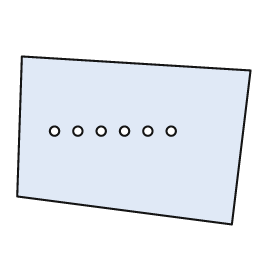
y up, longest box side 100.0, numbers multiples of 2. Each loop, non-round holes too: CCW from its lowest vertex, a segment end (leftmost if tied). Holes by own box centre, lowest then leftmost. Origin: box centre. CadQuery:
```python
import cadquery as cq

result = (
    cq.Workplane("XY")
    .moveTo(42.0, -36.0)
    .lineTo(50.0, 30.0)
    .lineTo(-48.0, 36.0)
    .lineTo(-50.0, -24.0)
    .close()
    .moveTo(-34.0, 4.0)
    .circle(2.0)
    .moveTo(-24.0, 4.0)
    .circle(2.0)
    .moveTo(-14.0, 4.0)
    .circle(2.0)
    .moveTo(-4.0, 4.0)
    .circle(2.0)
    .moveTo(6.0, 4.0)
    .circle(2.0)
    .moveTo(16.0, 4.0)
    .circle(2.0)
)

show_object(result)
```